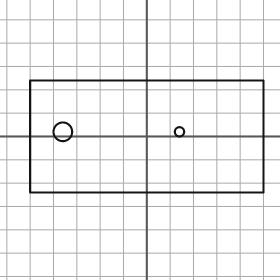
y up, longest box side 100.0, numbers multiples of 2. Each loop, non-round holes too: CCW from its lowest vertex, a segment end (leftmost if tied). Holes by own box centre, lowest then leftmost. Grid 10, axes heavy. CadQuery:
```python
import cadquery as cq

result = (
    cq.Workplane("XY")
    .moveTo(-50.0, -24.0)
    .lineTo(50.0, -24.0)
    .lineTo(50.0, 24.0)
    .lineTo(-50.0, 24.0)
    .close()
    .moveTo(-36.0, 2.0)
    .circle(4.0)
    .moveTo(14.0, 2.0)
    .circle(2.0)
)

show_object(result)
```